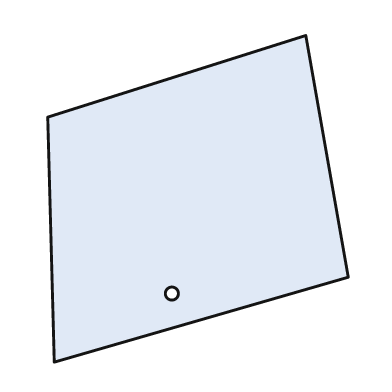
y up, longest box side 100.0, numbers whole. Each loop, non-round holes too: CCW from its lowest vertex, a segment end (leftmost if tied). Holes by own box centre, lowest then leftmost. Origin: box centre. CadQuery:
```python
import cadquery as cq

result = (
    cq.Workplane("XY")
    .moveTo(-44.0, -50.0)
    .lineTo(46.0, -24.0)
    .lineTo(33.0, 50.0)
    .lineTo(-46.0, 25.0)
    .close()
    .moveTo(-8.0, -29.0)
    .circle(2.0)
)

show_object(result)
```